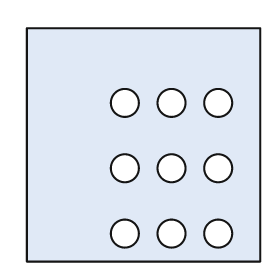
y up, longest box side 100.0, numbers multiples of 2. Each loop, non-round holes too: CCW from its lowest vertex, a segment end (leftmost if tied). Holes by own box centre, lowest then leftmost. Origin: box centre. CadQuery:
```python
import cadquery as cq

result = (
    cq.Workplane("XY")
    .moveTo(-50.0, -50.0)
    .lineTo(50.0, -50.0)
    .lineTo(50.0, 50.0)
    .lineTo(-50.0, 50.0)
    .close()
    .moveTo(-8.0, -38.0)
    .circle(6.0)
    .moveTo(12.0, -38.0)
    .circle(6.0)
    .moveTo(32.0, -38.0)
    .circle(6.0)
    .moveTo(-8.0, -10.0)
    .circle(6.0)
    .moveTo(12.0, -10.0)
    .circle(6.0)
    .moveTo(32.0, -10.0)
    .circle(6.0)
    .moveTo(-8.0, 18.0)
    .circle(6.0)
    .moveTo(12.0, 18.0)
    .circle(6.0)
    .moveTo(32.0, 18.0)
    .circle(6.0)
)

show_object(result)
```